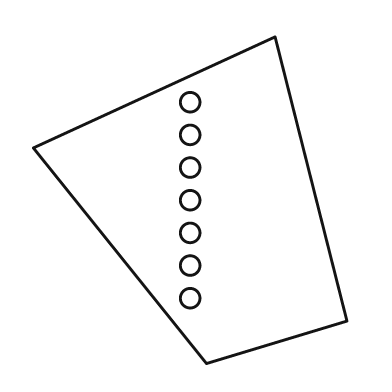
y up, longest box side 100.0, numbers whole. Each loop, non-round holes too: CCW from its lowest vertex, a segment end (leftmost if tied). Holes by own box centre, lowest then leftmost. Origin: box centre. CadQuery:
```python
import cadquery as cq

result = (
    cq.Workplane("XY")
    .moveTo(5.0, -50.0)
    .lineTo(48.0, -37.0)
    .lineTo(26.0, 50.0)
    .lineTo(-48.0, 16.0)
    .close()
    .moveTo(0.0, -30.0)
    .circle(3.0)
    .moveTo(0.0, -20.0)
    .circle(3.0)
    .moveTo(0.0, -10.0)
    .circle(3.0)
    .moveTo(0.0, 0.0)
    .circle(3.0)
    .moveTo(0.0, 10.0)
    .circle(3.0)
    .moveTo(0.0, 20.0)
    .circle(3.0)
    .moveTo(0.0, 30.0)
    .circle(3.0)
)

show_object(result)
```